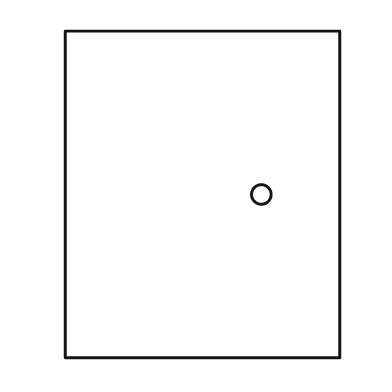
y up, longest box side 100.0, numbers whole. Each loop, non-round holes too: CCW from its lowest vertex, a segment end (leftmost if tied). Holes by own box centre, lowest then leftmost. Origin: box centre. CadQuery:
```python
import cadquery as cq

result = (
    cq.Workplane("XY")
    .moveTo(-42.0, -50.0)
    .lineTo(42.0, -50.0)
    .lineTo(42.0, 50.0)
    .lineTo(-42.0, 50.0)
    .close()
    .moveTo(18.0, 0.0)
    .circle(3.0)
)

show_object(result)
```